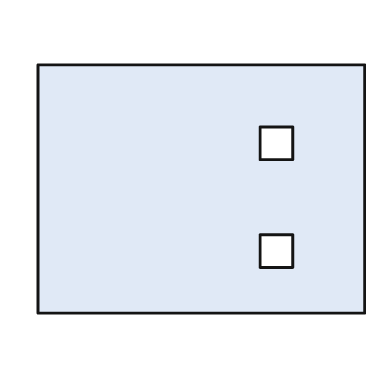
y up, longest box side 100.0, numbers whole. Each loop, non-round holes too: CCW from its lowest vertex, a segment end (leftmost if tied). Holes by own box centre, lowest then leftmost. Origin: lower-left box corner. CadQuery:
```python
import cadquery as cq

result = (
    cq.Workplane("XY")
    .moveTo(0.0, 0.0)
    .lineTo(100.0, 0.0)
    .lineTo(100.0, 76.0)
    .lineTo(0.0, 76.0)
    .close()
    .moveTo(68.0, 14.0)
    .lineTo(78.0, 14.0)
    .lineTo(78.0, 24.0)
    .lineTo(68.0, 24.0)
    .close()
    .moveTo(68.0, 47.0)
    .lineTo(78.0, 47.0)
    .lineTo(78.0, 57.0)
    .lineTo(68.0, 57.0)
    .close()
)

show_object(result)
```